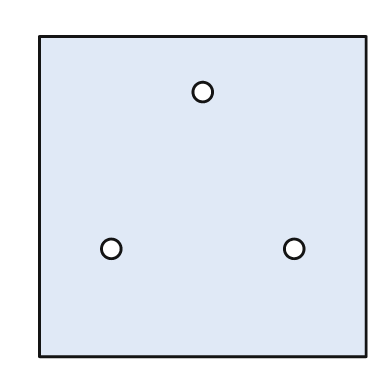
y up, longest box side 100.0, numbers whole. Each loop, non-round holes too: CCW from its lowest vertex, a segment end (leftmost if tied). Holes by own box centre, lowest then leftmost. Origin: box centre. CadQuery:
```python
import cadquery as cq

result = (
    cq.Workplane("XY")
    .moveTo(-50.0, -49.0)
    .lineTo(50.0, -49.0)
    .lineTo(50.0, 49.0)
    .lineTo(-50.0, 49.0)
    .close()
    .moveTo(-28.0, -16.0)
    .circle(3.0)
    .moveTo(28.0, -16.0)
    .circle(3.0)
    .moveTo(0.0, 32.0)
    .circle(3.0)
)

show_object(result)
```